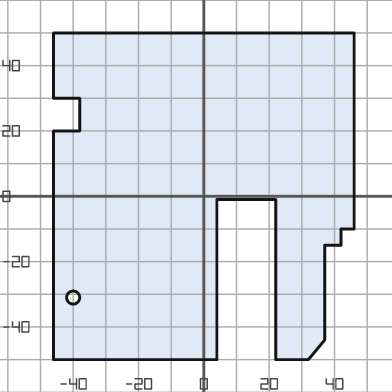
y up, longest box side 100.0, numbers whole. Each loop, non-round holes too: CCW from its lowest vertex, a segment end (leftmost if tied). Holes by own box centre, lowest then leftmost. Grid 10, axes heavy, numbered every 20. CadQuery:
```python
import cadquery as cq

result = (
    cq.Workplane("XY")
    .moveTo(-46.0, -50.0)
    .lineTo(4.0, -50.0)
    .lineTo(4.0, -1.0)
    .lineTo(22.0, -1.0)
    .lineTo(22.0, -50.0)
    .lineTo(32.0, -50.0)
    .lineTo(37.0, -44.0)
    .lineTo(37.0, -15.0)
    .lineTo(42.0, -15.0)
    .lineTo(42.0, -10.0)
    .lineTo(46.0, -10.0)
    .lineTo(46.0, 50.0)
    .lineTo(-46.0, 50.0)
    .lineTo(-46.0, 30.0)
    .lineTo(-38.0, 30.0)
    .lineTo(-38.0, 20.0)
    .lineTo(-46.0, 20.0)
    .close()
    .moveTo(-40.0, -31.0)
    .circle(2.0)
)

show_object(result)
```